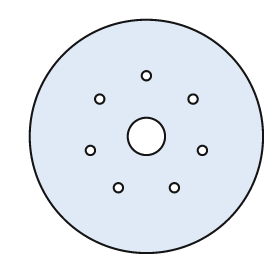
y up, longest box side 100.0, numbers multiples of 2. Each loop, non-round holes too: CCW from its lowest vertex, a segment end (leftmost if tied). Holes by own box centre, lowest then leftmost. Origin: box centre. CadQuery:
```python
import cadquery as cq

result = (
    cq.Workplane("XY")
    .moveTo(0.0, 0.0)
    .circle(50.0)
    .moveTo(-12.0, -22.0)
    .circle(2.0)
    .moveTo(12.0, -22.0)
    .circle(2.0)
    .moveTo(-24.0, -6.0)
    .circle(2.0)
    .moveTo(24.0, -6.0)
    .circle(2.0)
    .moveTo(0.0, 0.0)
    .circle(8.0)
    .moveTo(-20.0, 16.0)
    .circle(2.0)
    .moveTo(20.0, 16.0)
    .circle(2.0)
    .moveTo(0.0, 26.0)
    .circle(2.0)
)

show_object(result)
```